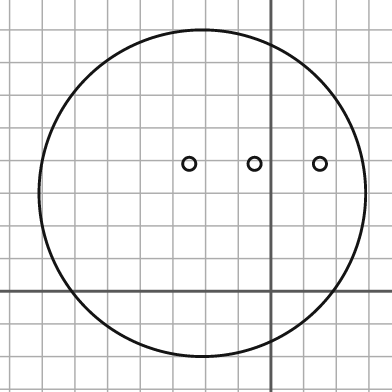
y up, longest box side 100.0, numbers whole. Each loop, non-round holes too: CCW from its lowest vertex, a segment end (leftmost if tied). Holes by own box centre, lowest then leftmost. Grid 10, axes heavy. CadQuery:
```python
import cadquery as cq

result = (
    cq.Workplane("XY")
    .moveTo(-21.0, 30.0)
    .circle(50.0)
    .moveTo(-25.0, 39.0)
    .circle(2.0)
    .moveTo(-5.0, 39.0)
    .circle(2.0)
    .moveTo(15.0, 39.0)
    .circle(2.0)
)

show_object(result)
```